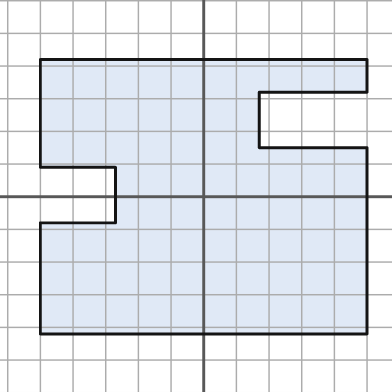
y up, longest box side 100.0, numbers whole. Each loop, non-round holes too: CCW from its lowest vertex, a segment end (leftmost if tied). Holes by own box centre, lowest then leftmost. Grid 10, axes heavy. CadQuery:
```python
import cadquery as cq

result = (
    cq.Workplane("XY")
    .moveTo(-50.0, -42.0)
    .lineTo(50.0, -42.0)
    .lineTo(50.0, 15.0)
    .lineTo(17.0, 15.0)
    .lineTo(17.0, 32.0)
    .lineTo(50.0, 32.0)
    .lineTo(50.0, 42.0)
    .lineTo(-50.0, 42.0)
    .lineTo(-50.0, 9.0)
    .lineTo(-27.0, 9.0)
    .lineTo(-27.0, -8.0)
    .lineTo(-50.0, -8.0)
    .close()
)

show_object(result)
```